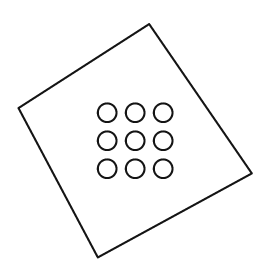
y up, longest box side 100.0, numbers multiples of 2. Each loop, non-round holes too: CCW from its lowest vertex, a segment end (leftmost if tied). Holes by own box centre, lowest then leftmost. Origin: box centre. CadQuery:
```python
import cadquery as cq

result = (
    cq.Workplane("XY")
    .moveTo(-16.0, -50.0)
    .lineTo(50.0, -14.0)
    .lineTo(6.0, 50.0)
    .lineTo(-50.0, 14.0)
    .close()
    .moveTo(-12.0, -12.0)
    .circle(4.0)
    .moveTo(0.0, -12.0)
    .circle(4.0)
    .moveTo(12.0, -12.0)
    .circle(4.0)
    .moveTo(-12.0, 0.0)
    .circle(4.0)
    .moveTo(0.0, 0.0)
    .circle(4.0)
    .moveTo(12.0, 0.0)
    .circle(4.0)
    .moveTo(-12.0, 12.0)
    .circle(4.0)
    .moveTo(0.0, 12.0)
    .circle(4.0)
    .moveTo(12.0, 12.0)
    .circle(4.0)
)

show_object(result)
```